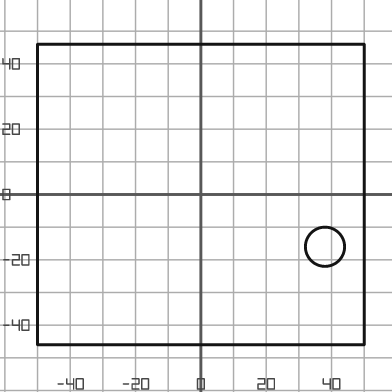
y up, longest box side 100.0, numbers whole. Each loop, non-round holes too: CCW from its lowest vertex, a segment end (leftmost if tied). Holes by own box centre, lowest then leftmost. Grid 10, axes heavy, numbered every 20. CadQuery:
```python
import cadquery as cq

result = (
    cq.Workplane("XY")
    .moveTo(-50.0, -46.0)
    .lineTo(50.0, -46.0)
    .lineTo(50.0, 46.0)
    .lineTo(-50.0, 46.0)
    .close()
    .moveTo(38.0, -16.0)
    .circle(6.0)
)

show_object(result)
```